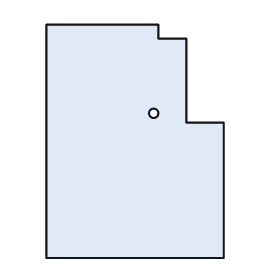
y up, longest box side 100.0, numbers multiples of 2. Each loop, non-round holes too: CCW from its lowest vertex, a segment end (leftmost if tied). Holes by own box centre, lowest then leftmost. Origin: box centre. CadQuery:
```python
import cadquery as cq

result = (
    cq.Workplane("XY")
    .moveTo(-38.0, -50.0)
    .lineTo(38.0, -50.0)
    .lineTo(38.0, 8.0)
    .lineTo(22.0, 8.0)
    .lineTo(22.0, 44.0)
    .lineTo(10.0, 44.0)
    .lineTo(10.0, 50.0)
    .lineTo(-38.0, 50.0)
    .close()
    .moveTo(8.0, 12.0)
    .circle(2.0)
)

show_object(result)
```